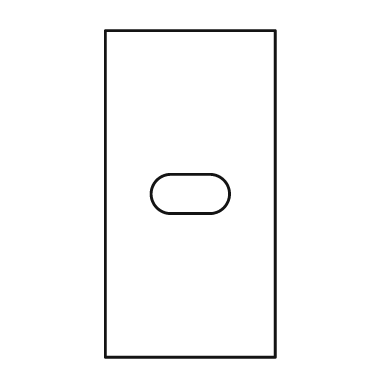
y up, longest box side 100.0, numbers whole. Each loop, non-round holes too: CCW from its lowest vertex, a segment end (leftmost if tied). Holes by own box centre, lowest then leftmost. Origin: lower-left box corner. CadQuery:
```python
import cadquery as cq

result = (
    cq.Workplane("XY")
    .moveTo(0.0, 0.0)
    .lineTo(52.0, 0.0)
    .lineTo(52.0, 100.0)
    .lineTo(0.0, 100.0)
    .close()
    .moveTo(20.0, 44.0)
    .lineTo(32.0, 44.0)
    .threePointArc((38.0, 50.0), (32.0, 56.0))
    .lineTo(20.0, 56.0)
    .threePointArc((14.0, 50.0), (20.0, 44.0))
    .close()
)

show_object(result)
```